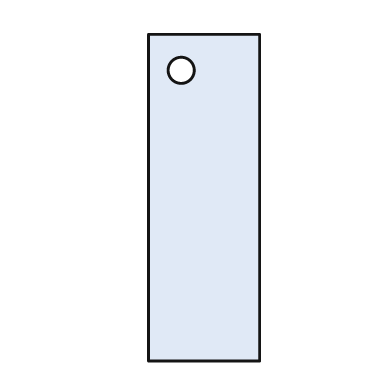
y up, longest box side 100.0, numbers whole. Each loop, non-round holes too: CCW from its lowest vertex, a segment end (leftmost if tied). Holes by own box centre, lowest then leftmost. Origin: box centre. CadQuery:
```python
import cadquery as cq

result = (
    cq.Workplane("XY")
    .moveTo(-17.0, -50.0)
    .lineTo(17.0, -50.0)
    .lineTo(17.0, 50.0)
    .lineTo(-17.0, 50.0)
    .close()
    .moveTo(-7.0, 39.0)
    .circle(4.0)
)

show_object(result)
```